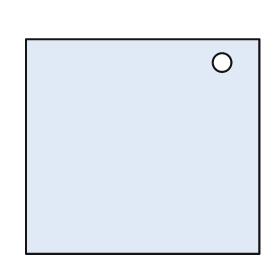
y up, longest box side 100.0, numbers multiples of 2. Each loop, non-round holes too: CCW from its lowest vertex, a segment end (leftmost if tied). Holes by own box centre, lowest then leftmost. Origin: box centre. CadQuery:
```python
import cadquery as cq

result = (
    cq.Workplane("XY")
    .moveTo(-50.0, -46.0)
    .lineTo(50.0, -46.0)
    .lineTo(50.0, 46.0)
    .lineTo(-50.0, 46.0)
    .close()
    .moveTo(34.0, 36.0)
    .circle(4.0)
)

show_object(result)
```